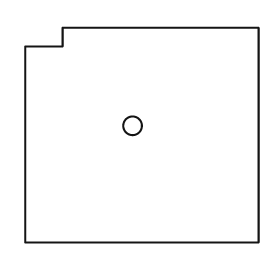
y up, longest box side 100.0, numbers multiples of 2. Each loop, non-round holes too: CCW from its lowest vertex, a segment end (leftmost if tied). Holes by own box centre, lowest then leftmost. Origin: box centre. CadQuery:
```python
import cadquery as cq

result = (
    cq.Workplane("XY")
    .moveTo(-50.0, -46.0)
    .lineTo(50.0, -46.0)
    .lineTo(50.0, 46.0)
    .lineTo(-34.0, 46.0)
    .lineTo(-34.0, 38.0)
    .lineTo(-50.0, 38.0)
    .close()
    .moveTo(-4.0, 4.0)
    .circle(4.0)
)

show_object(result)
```